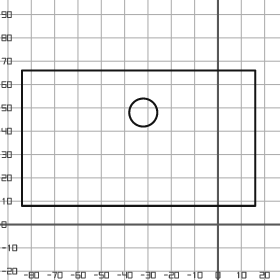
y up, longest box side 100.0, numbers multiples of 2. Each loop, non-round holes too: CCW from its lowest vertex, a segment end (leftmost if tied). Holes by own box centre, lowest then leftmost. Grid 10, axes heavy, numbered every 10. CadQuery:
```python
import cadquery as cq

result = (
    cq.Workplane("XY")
    .moveTo(-84.0, 8.0)
    .lineTo(16.0, 8.0)
    .lineTo(16.0, 66.0)
    .lineTo(-84.0, 66.0)
    .close()
    .moveTo(-32.0, 48.0)
    .circle(6.0)
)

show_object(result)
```